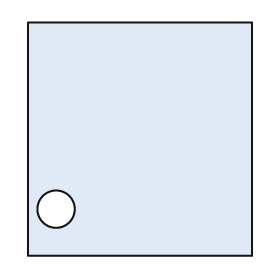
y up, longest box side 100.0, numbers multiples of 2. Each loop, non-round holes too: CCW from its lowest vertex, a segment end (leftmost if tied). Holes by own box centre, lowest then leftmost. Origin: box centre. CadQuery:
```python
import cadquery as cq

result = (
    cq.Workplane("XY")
    .moveTo(-48.0, -50.0)
    .lineTo(48.0, -50.0)
    .lineTo(48.0, 50.0)
    .lineTo(-48.0, 50.0)
    .close()
    .moveTo(-36.0, -30.0)
    .circle(8.0)
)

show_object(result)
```